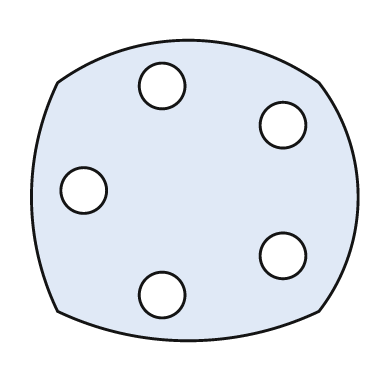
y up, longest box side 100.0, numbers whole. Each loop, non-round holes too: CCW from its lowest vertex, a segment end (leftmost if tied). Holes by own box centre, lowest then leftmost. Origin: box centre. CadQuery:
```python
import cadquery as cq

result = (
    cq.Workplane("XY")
    .moveTo(-42.0, -37.0)
    .threePointArc((-2.0, -46.0), (38.0, -37.0))
    .threePointArc((50.0, -2.0), (38.0, 33.0))
    .threePointArc((-2.0, 46.0), (-42.0, 33.0))
    .threePointArc((-50.0, -2.0), (-42.0, -37.0))
    .close()
    .moveTo(-10.0, -32.0)
    .circle(7.0)
    .moveTo(27.0, -20.0)
    .circle(7.0)
    .moveTo(-34.0, 0.0)
    .circle(7.0)
    .moveTo(27.0, 20.0)
    .circle(7.0)
    .moveTo(-10.0, 32.0)
    .circle(7.0)
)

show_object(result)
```